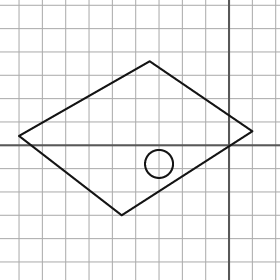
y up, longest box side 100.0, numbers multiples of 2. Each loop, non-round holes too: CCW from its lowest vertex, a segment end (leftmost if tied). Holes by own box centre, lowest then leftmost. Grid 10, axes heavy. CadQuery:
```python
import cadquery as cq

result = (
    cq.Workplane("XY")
    .moveTo(-46.0, -30.0)
    .lineTo(10.0, 6.0)
    .lineTo(-34.0, 36.0)
    .lineTo(-90.0, 4.0)
    .close()
    .moveTo(-30.0, -8.0)
    .circle(6.0)
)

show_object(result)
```